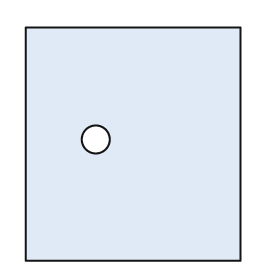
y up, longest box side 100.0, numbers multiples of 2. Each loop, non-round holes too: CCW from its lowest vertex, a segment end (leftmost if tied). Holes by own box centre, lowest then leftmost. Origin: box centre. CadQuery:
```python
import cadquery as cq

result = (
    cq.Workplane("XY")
    .moveTo(-46.0, -50.0)
    .lineTo(46.0, -50.0)
    .lineTo(46.0, 50.0)
    .lineTo(-46.0, 50.0)
    .close()
    .moveTo(-16.0, 2.0)
    .circle(6.0)
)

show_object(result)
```